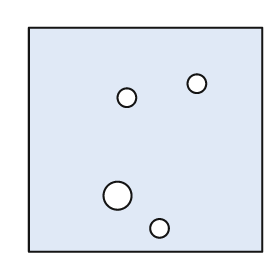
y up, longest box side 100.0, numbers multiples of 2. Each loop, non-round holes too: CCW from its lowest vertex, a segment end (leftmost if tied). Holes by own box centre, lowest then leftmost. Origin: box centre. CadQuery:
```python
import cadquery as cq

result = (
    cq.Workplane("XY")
    .moveTo(-50.0, -48.0)
    .lineTo(50.0, -48.0)
    .lineTo(50.0, 48.0)
    .lineTo(-50.0, 48.0)
    .close()
    .moveTo(6.0, -38.0)
    .circle(4.0)
    .moveTo(-12.0, -24.0)
    .circle(6.0)
    .moveTo(-8.0, 18.0)
    .circle(4.0)
    .moveTo(22.0, 24.0)
    .circle(4.0)
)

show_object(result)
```